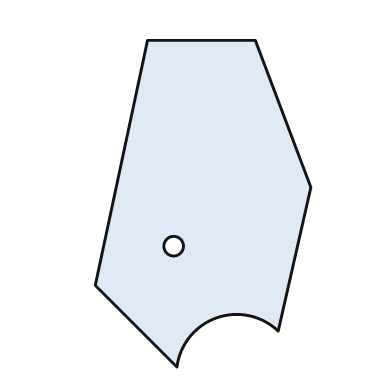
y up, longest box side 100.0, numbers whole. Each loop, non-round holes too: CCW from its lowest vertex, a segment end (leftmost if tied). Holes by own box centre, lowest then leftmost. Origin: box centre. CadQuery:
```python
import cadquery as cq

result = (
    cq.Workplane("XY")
    .moveTo(-8.0, -50.0)
    .threePointArc((4.0, -35.0), (23.0, -39.0))
    .lineTo(33.0, 5.0)
    .lineTo(16.0, 50.0)
    .lineTo(-17.0, 50.0)
    .lineTo(-33.0, -25.0)
    .close()
    .moveTo(-9.0, -13.0)
    .circle(3.0)
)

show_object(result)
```